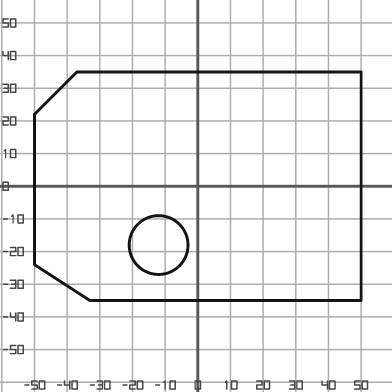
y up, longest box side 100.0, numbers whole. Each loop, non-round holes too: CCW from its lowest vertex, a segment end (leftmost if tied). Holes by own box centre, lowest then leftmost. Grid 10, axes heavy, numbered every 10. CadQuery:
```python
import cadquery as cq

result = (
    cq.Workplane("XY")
    .moveTo(-33.0, -35.0)
    .lineTo(50.0, -35.0)
    .lineTo(50.0, 35.0)
    .lineTo(-37.0, 35.0)
    .lineTo(-50.0, 22.0)
    .lineTo(-50.0, -24.0)
    .close()
    .moveTo(-12.0, -18.0)
    .circle(9.0)
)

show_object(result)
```